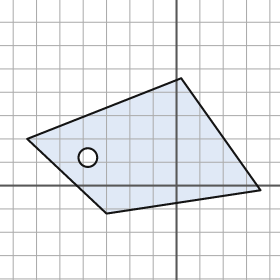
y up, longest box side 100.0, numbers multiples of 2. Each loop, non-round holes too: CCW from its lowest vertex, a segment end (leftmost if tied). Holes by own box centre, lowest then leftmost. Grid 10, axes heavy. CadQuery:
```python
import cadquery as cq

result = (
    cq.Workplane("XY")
    .moveTo(-30.0, -12.0)
    .lineTo(36.0, -2.0)
    .lineTo(2.0, 46.0)
    .lineTo(-64.0, 20.0)
    .close()
    .moveTo(-38.0, 12.0)
    .circle(4.0)
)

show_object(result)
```